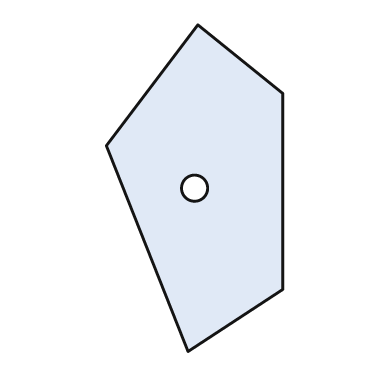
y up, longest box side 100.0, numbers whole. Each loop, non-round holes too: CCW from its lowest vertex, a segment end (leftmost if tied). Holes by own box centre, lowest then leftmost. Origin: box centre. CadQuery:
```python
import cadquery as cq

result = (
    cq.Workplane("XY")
    .moveTo(-2.0, -50.0)
    .lineTo(27.0, -31.0)
    .lineTo(27.0, 29.0)
    .lineTo(1.0, 50.0)
    .lineTo(-27.0, 13.0)
    .close()
    .moveTo(0.0, 0.0)
    .circle(4.0)
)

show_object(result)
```